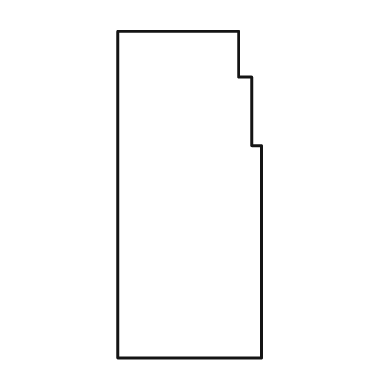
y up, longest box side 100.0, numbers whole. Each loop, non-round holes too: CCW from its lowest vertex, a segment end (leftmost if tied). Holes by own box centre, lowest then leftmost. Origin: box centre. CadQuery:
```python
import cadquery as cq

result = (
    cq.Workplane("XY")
    .moveTo(-22.0, -50.0)
    .lineTo(22.0, -50.0)
    .lineTo(22.0, 15.0)
    .lineTo(19.0, 15.0)
    .lineTo(19.0, 36.0)
    .lineTo(15.0, 36.0)
    .lineTo(15.0, 50.0)
    .lineTo(-22.0, 50.0)
    .close()
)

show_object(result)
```